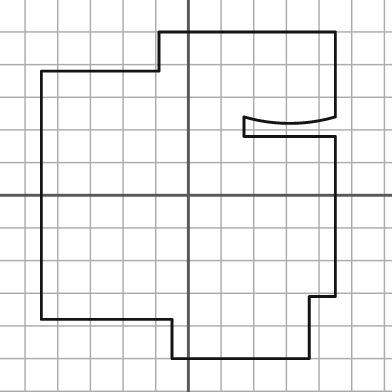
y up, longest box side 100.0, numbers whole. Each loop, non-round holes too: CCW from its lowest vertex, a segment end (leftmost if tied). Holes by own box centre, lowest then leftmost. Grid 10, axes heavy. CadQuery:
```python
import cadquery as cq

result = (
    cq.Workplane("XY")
    .moveTo(-5.0, -50.0)
    .lineTo(37.0, -50.0)
    .lineTo(37.0, -31.0)
    .lineTo(45.0, -31.0)
    .lineTo(45.0, 18.0)
    .lineTo(17.0, 18.0)
    .lineTo(17.0, 24.0)
    .threePointArc((31.0, 22.0), (45.0, 24.0))
    .lineTo(45.0, 50.0)
    .lineTo(-9.0, 50.0)
    .lineTo(-9.0, 38.0)
    .lineTo(-45.0, 38.0)
    .lineTo(-45.0, -38.0)
    .lineTo(-5.0, -38.0)
    .close()
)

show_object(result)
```